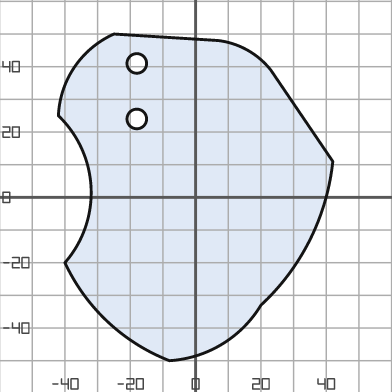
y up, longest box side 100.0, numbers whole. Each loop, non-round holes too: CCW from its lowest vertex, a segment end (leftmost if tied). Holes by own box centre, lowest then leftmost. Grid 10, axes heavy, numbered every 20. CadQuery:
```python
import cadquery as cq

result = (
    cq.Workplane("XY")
    .moveTo(-8.0, -50.0)
    .threePointArc((8.0, -45.0), (20.0, -33.0))
    .threePointArc((35.0, -13.0), (42.0, 11.0))
    .lineTo(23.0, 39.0)
    .threePointArc((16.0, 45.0), (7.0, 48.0))
    .lineTo(-25.0, 50.0)
    .threePointArc((-37.0, 40.0), (-42.0, 25.0))
    .threePointArc((-32.0, 3.0), (-40.0, -20.0))
    .threePointArc((-27.0, -38.0), (-8.0, -50.0))
    .close()
    .moveTo(-18.0, 24.0)
    .circle(3.0)
    .moveTo(-18.0, 41.0)
    .circle(3.0)
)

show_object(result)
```